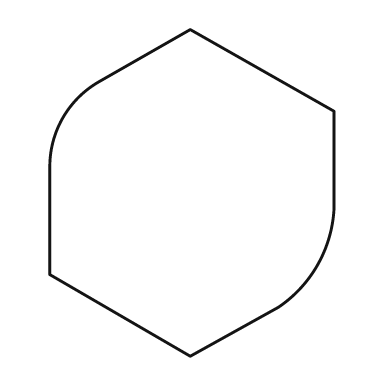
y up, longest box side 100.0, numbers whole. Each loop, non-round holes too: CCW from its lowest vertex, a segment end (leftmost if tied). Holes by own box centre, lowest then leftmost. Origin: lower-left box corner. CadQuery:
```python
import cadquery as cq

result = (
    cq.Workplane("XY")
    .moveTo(43.0, 0.0)
    .lineTo(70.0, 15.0)
    .threePointArc((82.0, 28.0), (87.0, 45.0))
    .lineTo(87.0, 75.0)
    .lineTo(43.0, 100.0)
    .lineTo(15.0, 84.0)
    .threePointArc((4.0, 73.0), (0.0, 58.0))
    .lineTo(0.0, 25.0)
    .close()
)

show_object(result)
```